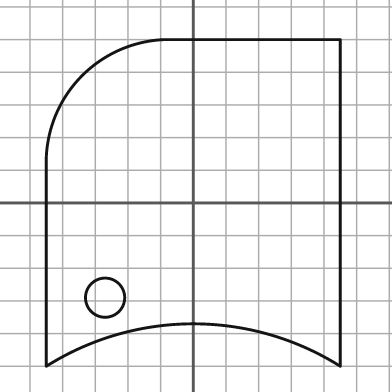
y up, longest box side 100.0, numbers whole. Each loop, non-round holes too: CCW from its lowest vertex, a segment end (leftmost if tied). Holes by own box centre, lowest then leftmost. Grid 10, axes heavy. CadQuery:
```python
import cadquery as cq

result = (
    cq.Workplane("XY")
    .moveTo(-45.0, -50.0)
    .threePointArc((0.0, -37.0), (45.0, -50.0))
    .lineTo(45.0, 50.0)
    .lineTo(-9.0, 50.0)
    .threePointArc((-34.0, 39.0), (-45.0, 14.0))
    .close()
    .moveTo(-27.0, -29.0)
    .circle(6.0)
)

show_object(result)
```